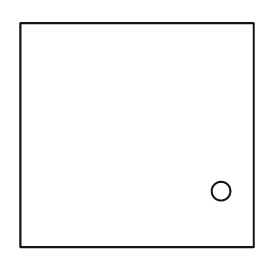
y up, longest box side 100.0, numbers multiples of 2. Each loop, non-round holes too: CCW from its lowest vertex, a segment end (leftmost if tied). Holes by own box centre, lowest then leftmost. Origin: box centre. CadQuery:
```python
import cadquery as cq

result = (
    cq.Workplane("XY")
    .moveTo(-50.0, -48.0)
    .lineTo(50.0, -48.0)
    .lineTo(50.0, 48.0)
    .lineTo(-50.0, 48.0)
    .close()
    .moveTo(36.0, -24.0)
    .circle(4.0)
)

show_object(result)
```